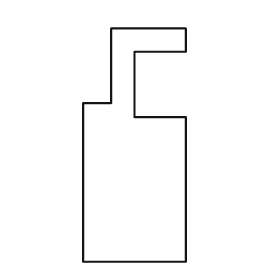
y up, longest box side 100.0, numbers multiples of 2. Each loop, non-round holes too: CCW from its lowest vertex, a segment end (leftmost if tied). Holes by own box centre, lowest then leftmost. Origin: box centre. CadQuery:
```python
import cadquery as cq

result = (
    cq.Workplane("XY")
    .moveTo(-22.0, -50.0)
    .lineTo(22.0, -50.0)
    .lineTo(22.0, 12.0)
    .lineTo(0.0, 12.0)
    .lineTo(0.0, 40.0)
    .lineTo(22.0, 40.0)
    .lineTo(22.0, 50.0)
    .lineTo(-10.0, 50.0)
    .lineTo(-10.0, 18.0)
    .lineTo(-22.0, 18.0)
    .close()
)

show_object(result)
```